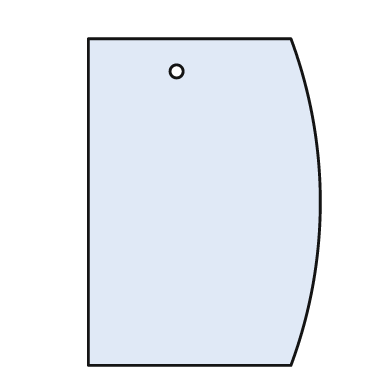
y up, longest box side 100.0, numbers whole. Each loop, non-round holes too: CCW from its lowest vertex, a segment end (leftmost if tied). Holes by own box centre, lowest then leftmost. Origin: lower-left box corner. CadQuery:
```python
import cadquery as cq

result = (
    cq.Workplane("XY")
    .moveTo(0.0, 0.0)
    .lineTo(62.0, 0.0)
    .threePointArc((71.0, 50.0), (62.0, 100.0))
    .lineTo(0.0, 100.0)
    .close()
    .moveTo(27.0, 90.0)
    .circle(2.0)
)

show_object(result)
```